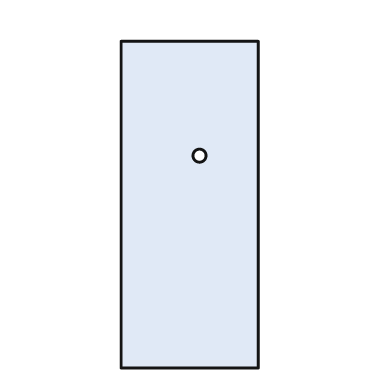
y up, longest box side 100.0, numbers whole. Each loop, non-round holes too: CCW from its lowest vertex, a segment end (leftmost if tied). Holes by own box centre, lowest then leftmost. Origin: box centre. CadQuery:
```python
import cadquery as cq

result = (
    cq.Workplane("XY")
    .moveTo(-21.0, -50.0)
    .lineTo(21.0, -50.0)
    .lineTo(21.0, 50.0)
    .lineTo(-21.0, 50.0)
    .close()
    .moveTo(3.0, 15.0)
    .circle(2.0)
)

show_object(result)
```